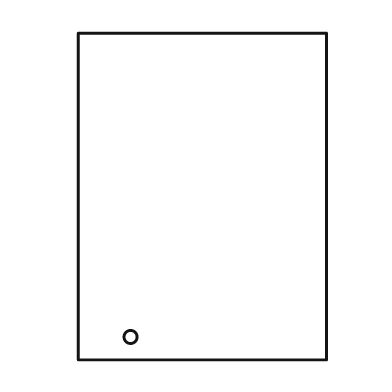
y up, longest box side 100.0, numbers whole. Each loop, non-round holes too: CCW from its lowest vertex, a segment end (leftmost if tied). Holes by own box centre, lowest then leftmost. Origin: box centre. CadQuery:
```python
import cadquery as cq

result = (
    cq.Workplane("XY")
    .moveTo(-38.0, -50.0)
    .lineTo(38.0, -50.0)
    .lineTo(38.0, 50.0)
    .lineTo(-38.0, 50.0)
    .close()
    .moveTo(-22.0, -43.0)
    .circle(2.0)
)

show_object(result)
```